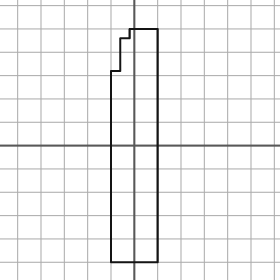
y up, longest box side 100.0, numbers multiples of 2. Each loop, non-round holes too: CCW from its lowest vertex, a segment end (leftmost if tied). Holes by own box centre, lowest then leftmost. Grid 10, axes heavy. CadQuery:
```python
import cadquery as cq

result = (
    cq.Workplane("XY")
    .moveTo(-10.0, -50.0)
    .lineTo(10.0, -50.0)
    .lineTo(10.0, 50.0)
    .lineTo(-2.0, 50.0)
    .lineTo(-2.0, 46.0)
    .lineTo(-6.0, 46.0)
    .lineTo(-6.0, 32.0)
    .lineTo(-10.0, 32.0)
    .close()
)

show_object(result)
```